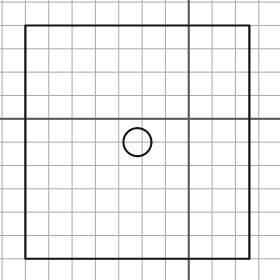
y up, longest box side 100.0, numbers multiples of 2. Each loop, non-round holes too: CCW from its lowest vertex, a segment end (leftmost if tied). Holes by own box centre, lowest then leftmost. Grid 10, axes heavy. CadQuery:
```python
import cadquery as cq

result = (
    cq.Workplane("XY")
    .moveTo(-70.0, -60.0)
    .lineTo(26.0, -60.0)
    .lineTo(26.0, 40.0)
    .lineTo(-70.0, 40.0)
    .close()
    .moveTo(-22.0, -10.0)
    .circle(6.0)
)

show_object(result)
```